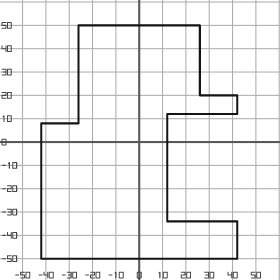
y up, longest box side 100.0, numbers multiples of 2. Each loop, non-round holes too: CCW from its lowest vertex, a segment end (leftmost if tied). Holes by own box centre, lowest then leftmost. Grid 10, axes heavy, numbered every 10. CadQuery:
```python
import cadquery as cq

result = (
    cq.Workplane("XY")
    .moveTo(-42.0, -50.0)
    .lineTo(42.0, -50.0)
    .lineTo(42.0, -34.0)
    .lineTo(12.0, -34.0)
    .lineTo(12.0, 12.0)
    .lineTo(42.0, 12.0)
    .lineTo(42.0, 20.0)
    .lineTo(26.0, 20.0)
    .lineTo(26.0, 50.0)
    .lineTo(-26.0, 50.0)
    .lineTo(-26.0, 8.0)
    .lineTo(-42.0, 8.0)
    .close()
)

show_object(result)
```